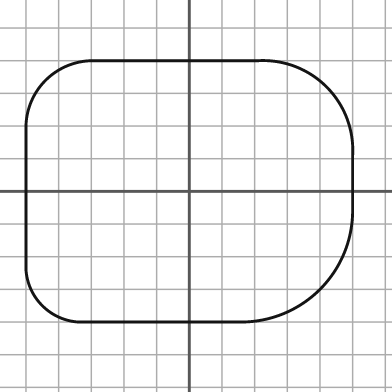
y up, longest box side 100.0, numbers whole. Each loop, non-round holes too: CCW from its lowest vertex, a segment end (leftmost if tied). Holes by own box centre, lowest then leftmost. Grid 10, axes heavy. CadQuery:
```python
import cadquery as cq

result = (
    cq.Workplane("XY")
    .moveTo(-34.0, -40.0)
    .lineTo(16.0, -40.0)
    .threePointArc((40.0, -30.0), (50.0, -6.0))
    .lineTo(50.0, 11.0)
    .threePointArc((42.0, 32.0), (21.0, 40.0))
    .lineTo(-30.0, 40.0)
    .threePointArc((-44.0, 34.0), (-50.0, 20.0))
    .lineTo(-50.0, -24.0)
    .threePointArc((-45.0, -35.0), (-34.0, -40.0))
    .close()
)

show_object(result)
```